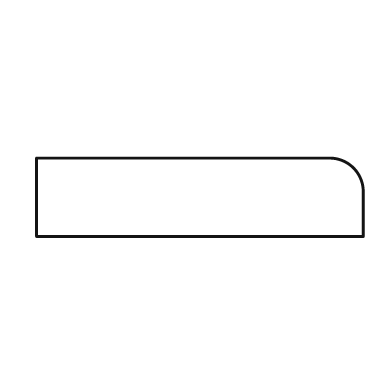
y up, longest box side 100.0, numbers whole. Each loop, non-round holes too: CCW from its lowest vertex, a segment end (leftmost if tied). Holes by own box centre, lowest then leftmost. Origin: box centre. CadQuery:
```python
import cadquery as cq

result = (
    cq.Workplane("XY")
    .moveTo(-50.0, -12.0)
    .lineTo(50.0, -12.0)
    .lineTo(50.0, 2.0)
    .threePointArc((47.0, 9.0), (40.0, 12.0))
    .lineTo(-50.0, 12.0)
    .close()
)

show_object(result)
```